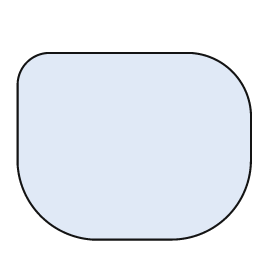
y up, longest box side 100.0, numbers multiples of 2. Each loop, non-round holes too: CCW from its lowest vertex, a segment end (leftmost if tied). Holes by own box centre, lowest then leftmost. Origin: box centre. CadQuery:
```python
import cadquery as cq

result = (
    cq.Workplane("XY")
    .moveTo(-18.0, -40.0)
    .lineTo(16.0, -40.0)
    .threePointArc((40.0, -30.0), (50.0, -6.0))
    .lineTo(50.0, 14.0)
    .threePointArc((42.0, 32.0), (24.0, 40.0))
    .lineTo(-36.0, 40.0)
    .threePointArc((-46.0, 36.0), (-50.0, 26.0))
    .lineTo(-50.0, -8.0)
    .threePointArc((-40.0, -30.0), (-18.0, -40.0))
    .close()
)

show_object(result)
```